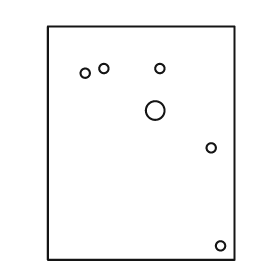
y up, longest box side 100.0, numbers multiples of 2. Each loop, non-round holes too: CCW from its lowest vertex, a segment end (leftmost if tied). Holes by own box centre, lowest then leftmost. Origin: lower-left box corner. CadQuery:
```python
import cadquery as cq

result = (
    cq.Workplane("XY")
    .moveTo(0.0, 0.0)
    .lineTo(80.0, 0.0)
    .lineTo(80.0, 100.0)
    .lineTo(0.0, 100.0)
    .close()
    .moveTo(74.0, 6.0)
    .circle(2.0)
    .moveTo(70.0, 48.0)
    .circle(2.0)
    .moveTo(46.0, 64.0)
    .circle(4.0)
    .moveTo(16.0, 80.0)
    .circle(2.0)
    .moveTo(24.0, 82.0)
    .circle(2.0)
    .moveTo(48.0, 82.0)
    .circle(2.0)
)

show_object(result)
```